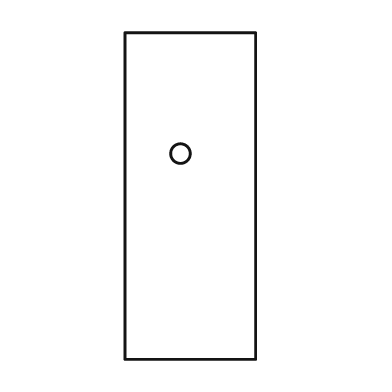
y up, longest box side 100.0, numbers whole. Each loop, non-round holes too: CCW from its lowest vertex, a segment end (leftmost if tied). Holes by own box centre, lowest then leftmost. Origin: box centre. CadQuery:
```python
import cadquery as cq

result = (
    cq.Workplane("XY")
    .moveTo(-20.0, -50.0)
    .lineTo(20.0, -50.0)
    .lineTo(20.0, 50.0)
    .lineTo(-20.0, 50.0)
    .close()
    .moveTo(-3.0, 13.0)
    .circle(3.0)
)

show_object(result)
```